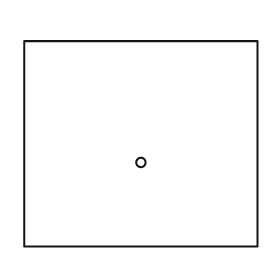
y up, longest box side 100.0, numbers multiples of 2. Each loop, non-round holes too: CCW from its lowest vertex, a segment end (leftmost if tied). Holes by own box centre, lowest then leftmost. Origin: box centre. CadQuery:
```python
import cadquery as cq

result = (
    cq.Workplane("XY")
    .moveTo(-50.0, -44.0)
    .lineTo(50.0, -44.0)
    .lineTo(50.0, 44.0)
    .lineTo(-50.0, 44.0)
    .close()
    .moveTo(0.0, -8.0)
    .circle(2.0)
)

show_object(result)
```